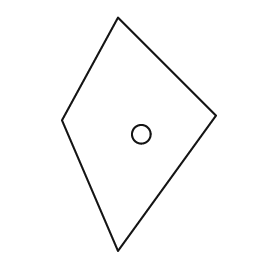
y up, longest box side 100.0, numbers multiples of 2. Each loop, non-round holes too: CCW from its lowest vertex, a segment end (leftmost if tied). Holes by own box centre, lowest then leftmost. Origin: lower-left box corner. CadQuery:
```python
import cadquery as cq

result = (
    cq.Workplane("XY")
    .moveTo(24.0, 0.0)
    .lineTo(66.0, 58.0)
    .lineTo(24.0, 100.0)
    .lineTo(0.0, 56.0)
    .close()
    .moveTo(34.0, 50.0)
    .circle(4.0)
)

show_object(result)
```